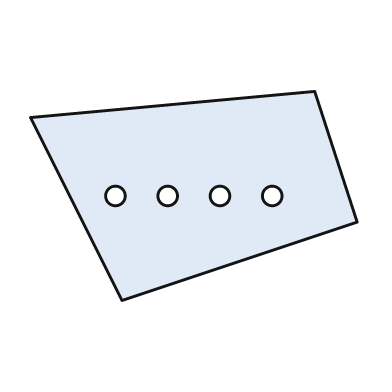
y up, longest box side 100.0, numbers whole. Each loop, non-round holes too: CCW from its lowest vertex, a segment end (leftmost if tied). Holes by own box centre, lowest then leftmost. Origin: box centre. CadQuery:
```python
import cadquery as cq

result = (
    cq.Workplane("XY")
    .moveTo(-22.0, -32.0)
    .lineTo(50.0, -8.0)
    .lineTo(37.0, 32.0)
    .lineTo(-50.0, 24.0)
    .close()
    .moveTo(-24.0, 0.0)
    .circle(3.0)
    .moveTo(-8.0, 0.0)
    .circle(3.0)
    .moveTo(8.0, 0.0)
    .circle(3.0)
    .moveTo(24.0, 0.0)
    .circle(3.0)
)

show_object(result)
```